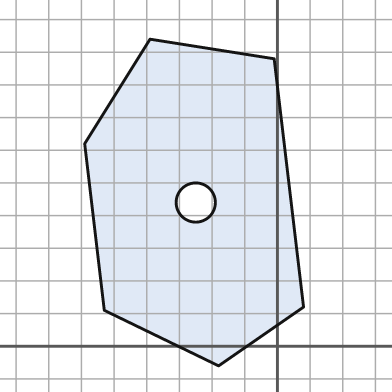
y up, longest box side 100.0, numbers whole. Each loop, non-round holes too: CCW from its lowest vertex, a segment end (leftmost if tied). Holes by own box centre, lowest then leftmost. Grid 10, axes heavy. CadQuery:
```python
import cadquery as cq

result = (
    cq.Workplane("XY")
    .moveTo(-18.0, -6.0)
    .lineTo(8.0, 12.0)
    .lineTo(-1.0, 88.0)
    .lineTo(-39.0, 94.0)
    .lineTo(-59.0, 62.0)
    .lineTo(-53.0, 11.0)
    .close()
    .moveTo(-25.0, 44.0)
    .circle(6.0)
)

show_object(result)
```